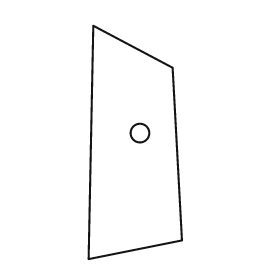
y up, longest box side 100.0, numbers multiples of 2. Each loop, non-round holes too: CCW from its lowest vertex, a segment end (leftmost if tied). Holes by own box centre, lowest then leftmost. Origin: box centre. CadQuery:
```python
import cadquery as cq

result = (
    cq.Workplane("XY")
    .moveTo(-20.0, -50.0)
    .lineTo(20.0, -42.0)
    .lineTo(16.0, 32.0)
    .lineTo(-18.0, 50.0)
    .close()
    .moveTo(2.0, 4.0)
    .circle(4.0)
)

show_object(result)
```